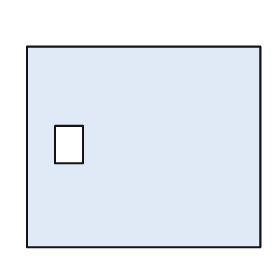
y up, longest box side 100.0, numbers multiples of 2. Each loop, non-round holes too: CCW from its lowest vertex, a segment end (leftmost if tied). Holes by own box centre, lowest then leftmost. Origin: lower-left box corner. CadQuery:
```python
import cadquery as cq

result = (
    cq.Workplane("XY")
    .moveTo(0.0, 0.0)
    .lineTo(100.0, 0.0)
    .lineTo(100.0, 86.0)
    .lineTo(0.0, 86.0)
    .close()
    .moveTo(12.0, 36.0)
    .lineTo(24.0, 36.0)
    .lineTo(24.0, 52.0)
    .lineTo(12.0, 52.0)
    .close()
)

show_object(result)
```